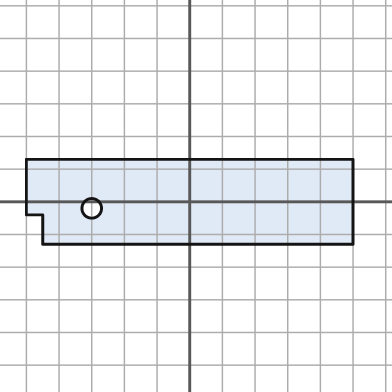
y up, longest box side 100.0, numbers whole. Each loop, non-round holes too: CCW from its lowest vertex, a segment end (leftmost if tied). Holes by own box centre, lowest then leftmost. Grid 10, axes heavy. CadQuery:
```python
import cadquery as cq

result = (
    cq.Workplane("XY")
    .moveTo(-45.0, -13.0)
    .lineTo(50.0, -13.0)
    .lineTo(50.0, 13.0)
    .lineTo(-50.0, 13.0)
    .lineTo(-50.0, -4.0)
    .lineTo(-45.0, -4.0)
    .close()
    .moveTo(-30.0, -2.0)
    .circle(3.0)
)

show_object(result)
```